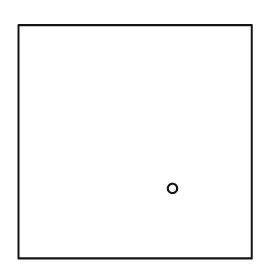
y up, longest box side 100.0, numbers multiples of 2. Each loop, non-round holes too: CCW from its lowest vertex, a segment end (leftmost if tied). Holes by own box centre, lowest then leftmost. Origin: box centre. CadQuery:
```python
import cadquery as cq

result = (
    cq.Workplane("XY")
    .moveTo(-50.0, -50.0)
    .lineTo(50.0, -50.0)
    .lineTo(50.0, 50.0)
    .lineTo(-50.0, 50.0)
    .close()
    .moveTo(16.0, -20.0)
    .circle(2.0)
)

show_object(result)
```